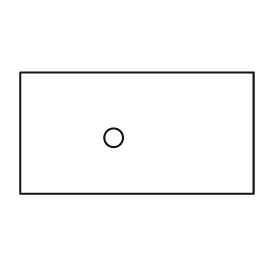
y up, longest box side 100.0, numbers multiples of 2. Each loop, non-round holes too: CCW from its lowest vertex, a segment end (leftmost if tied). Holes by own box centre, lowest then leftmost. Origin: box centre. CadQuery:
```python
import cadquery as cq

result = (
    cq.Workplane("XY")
    .moveTo(-50.0, -26.0)
    .lineTo(50.0, -26.0)
    .lineTo(50.0, 26.0)
    .lineTo(-50.0, 26.0)
    .close()
    .moveTo(-10.0, -2.0)
    .circle(4.0)
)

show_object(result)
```